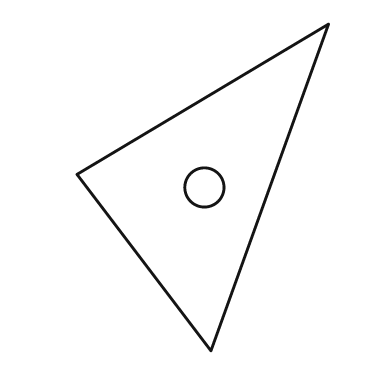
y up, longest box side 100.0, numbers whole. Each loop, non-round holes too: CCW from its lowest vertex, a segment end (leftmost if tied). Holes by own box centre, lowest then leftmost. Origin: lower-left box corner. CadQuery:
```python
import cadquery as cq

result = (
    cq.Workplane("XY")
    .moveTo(41.0, 0.0)
    .lineTo(77.0, 100.0)
    .lineTo(0.0, 54.0)
    .close()
    .moveTo(39.0, 50.0)
    .circle(6.0)
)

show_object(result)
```